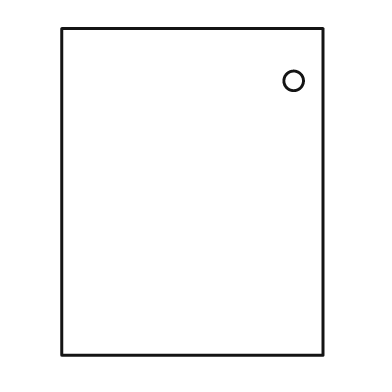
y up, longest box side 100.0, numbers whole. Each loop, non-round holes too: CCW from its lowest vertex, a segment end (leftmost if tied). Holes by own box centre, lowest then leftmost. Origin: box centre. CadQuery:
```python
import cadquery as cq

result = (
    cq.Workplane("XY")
    .moveTo(-40.0, -50.0)
    .lineTo(40.0, -50.0)
    .lineTo(40.0, 50.0)
    .lineTo(-40.0, 50.0)
    .close()
    .moveTo(31.0, 34.0)
    .circle(3.0)
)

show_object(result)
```